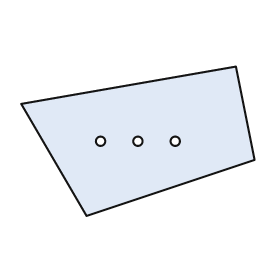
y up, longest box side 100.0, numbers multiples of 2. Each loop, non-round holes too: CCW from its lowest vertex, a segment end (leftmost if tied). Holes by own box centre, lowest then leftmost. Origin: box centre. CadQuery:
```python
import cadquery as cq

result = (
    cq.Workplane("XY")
    .moveTo(-22.0, -32.0)
    .lineTo(50.0, -8.0)
    .lineTo(42.0, 32.0)
    .lineTo(-50.0, 16.0)
    .close()
    .moveTo(-16.0, 0.0)
    .circle(2.0)
    .moveTo(0.0, 0.0)
    .circle(2.0)
    .moveTo(16.0, 0.0)
    .circle(2.0)
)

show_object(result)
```